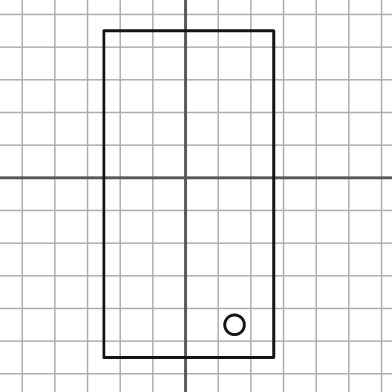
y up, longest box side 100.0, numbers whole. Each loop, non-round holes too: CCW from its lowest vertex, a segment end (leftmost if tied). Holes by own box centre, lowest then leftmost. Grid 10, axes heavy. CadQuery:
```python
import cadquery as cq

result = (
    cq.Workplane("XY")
    .moveTo(-25.0, -55.0)
    .lineTo(27.0, -55.0)
    .lineTo(27.0, 45.0)
    .lineTo(-25.0, 45.0)
    .close()
    .moveTo(15.0, -45.0)
    .circle(3.0)
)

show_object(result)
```